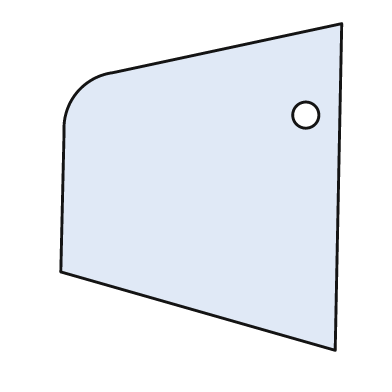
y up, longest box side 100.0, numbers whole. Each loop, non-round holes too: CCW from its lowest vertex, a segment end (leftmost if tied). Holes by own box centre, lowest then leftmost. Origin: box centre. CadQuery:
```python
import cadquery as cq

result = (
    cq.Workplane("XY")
    .moveTo(41.0, -50.0)
    .lineTo(43.0, 50.0)
    .lineTo(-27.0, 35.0)
    .threePointArc((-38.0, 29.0), (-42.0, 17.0))
    .lineTo(-43.0, -26.0)
    .close()
    .moveTo(32.0, 22.0)
    .circle(4.0)
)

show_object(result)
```